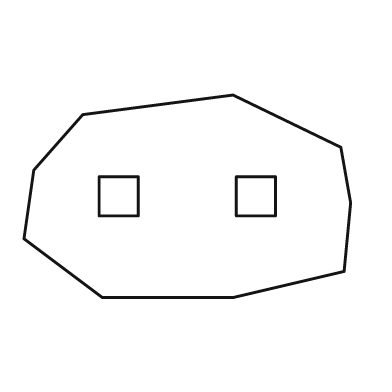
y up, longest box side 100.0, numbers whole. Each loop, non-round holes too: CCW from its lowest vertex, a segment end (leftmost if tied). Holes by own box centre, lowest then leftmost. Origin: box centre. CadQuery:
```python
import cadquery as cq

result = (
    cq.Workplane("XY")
    .moveTo(-26.0, -31.0)
    .lineTo(14.0, -31.0)
    .lineTo(48.0, -23.0)
    .lineTo(50.0, -2.0)
    .lineTo(47.0, 15.0)
    .lineTo(14.0, 31.0)
    .lineTo(-32.0, 25.0)
    .lineTo(-47.0, 8.0)
    .lineTo(-50.0, -13.0)
    .close()
    .moveTo(-27.0, -6.0)
    .lineTo(-15.0, -6.0)
    .lineTo(-15.0, 6.0)
    .lineTo(-27.0, 6.0)
    .close()
    .moveTo(15.0, -6.0)
    .lineTo(27.0, -6.0)
    .lineTo(27.0, 6.0)
    .lineTo(15.0, 6.0)
    .close()
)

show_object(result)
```